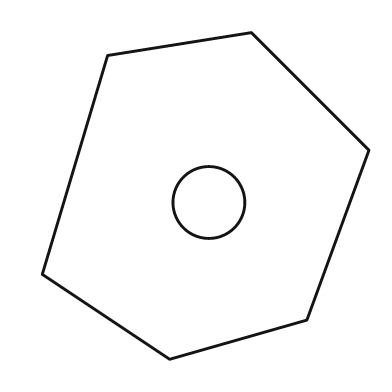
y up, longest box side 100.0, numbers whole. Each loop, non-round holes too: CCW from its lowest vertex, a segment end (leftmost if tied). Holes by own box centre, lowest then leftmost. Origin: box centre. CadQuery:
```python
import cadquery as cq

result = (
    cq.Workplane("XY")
    .moveTo(-11.0, -50.0)
    .lineTo(31.0, -38.0)
    .lineTo(50.0, 14.0)
    .lineTo(14.0, 50.0)
    .lineTo(-30.0, 43.0)
    .lineTo(-50.0, -24.0)
    .close()
    .moveTo(1.0, -2.0)
    .circle(11.0)
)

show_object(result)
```